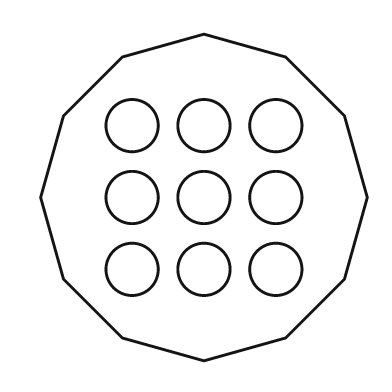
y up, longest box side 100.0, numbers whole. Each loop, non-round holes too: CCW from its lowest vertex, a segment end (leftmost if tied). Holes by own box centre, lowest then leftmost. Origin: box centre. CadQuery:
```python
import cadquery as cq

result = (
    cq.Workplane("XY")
    .moveTo(0.0, -50.0)
    .lineTo(25.0, -43.0)
    .lineTo(43.0, -25.0)
    .lineTo(50.0, 0.0)
    .lineTo(43.0, 25.0)
    .lineTo(25.0, 43.0)
    .lineTo(0.0, 50.0)
    .lineTo(-25.0, 43.0)
    .lineTo(-43.0, 25.0)
    .lineTo(-50.0, 0.0)
    .lineTo(-43.0, -25.0)
    .lineTo(-25.0, -43.0)
    .close()
    .moveTo(-22.0, -22.0)
    .circle(8.0)
    .moveTo(0.0, -22.0)
    .circle(8.0)
    .moveTo(22.0, -22.0)
    .circle(8.0)
    .moveTo(-22.0, 0.0)
    .circle(8.0)
    .moveTo(0.0, 0.0)
    .circle(8.0)
    .moveTo(22.0, 0.0)
    .circle(8.0)
    .moveTo(-22.0, 22.0)
    .circle(8.0)
    .moveTo(0.0, 22.0)
    .circle(8.0)
    .moveTo(22.0, 22.0)
    .circle(8.0)
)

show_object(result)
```